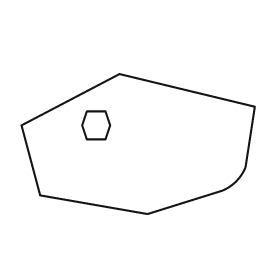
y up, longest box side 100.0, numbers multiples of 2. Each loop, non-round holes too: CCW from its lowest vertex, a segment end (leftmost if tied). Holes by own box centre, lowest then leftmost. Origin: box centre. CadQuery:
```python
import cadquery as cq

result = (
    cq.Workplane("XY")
    .moveTo(4.0, -30.0)
    .lineTo(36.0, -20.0)
    .threePointArc((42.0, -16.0), (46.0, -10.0))
    .lineTo(50.0, 16.0)
    .lineTo(-8.0, 30.0)
    .lineTo(-50.0, 8.0)
    .lineTo(-42.0, -22.0)
    .close()
    .moveTo(-22.0, 2.0)
    .lineTo(-14.0, 2.0)
    .lineTo(-12.0, 8.0)
    .lineTo(-14.0, 14.0)
    .lineTo(-22.0, 14.0)
    .lineTo(-24.0, 8.0)
    .close()
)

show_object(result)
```